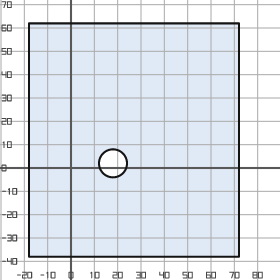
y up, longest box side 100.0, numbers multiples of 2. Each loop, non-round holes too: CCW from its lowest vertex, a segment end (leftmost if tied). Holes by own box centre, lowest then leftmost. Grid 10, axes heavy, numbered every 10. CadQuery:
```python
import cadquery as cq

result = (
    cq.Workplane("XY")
    .moveTo(-18.0, -38.0)
    .lineTo(72.0, -38.0)
    .lineTo(72.0, 62.0)
    .lineTo(-18.0, 62.0)
    .close()
    .moveTo(18.0, 2.0)
    .circle(6.0)
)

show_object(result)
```